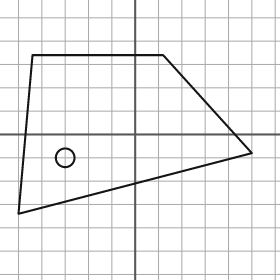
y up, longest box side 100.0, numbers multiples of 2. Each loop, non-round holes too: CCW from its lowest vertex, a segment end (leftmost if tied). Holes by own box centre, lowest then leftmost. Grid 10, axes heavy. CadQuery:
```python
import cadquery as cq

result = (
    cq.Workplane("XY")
    .moveTo(-50.0, -34.0)
    .lineTo(50.0, -8.0)
    .lineTo(12.0, 34.0)
    .lineTo(-44.0, 34.0)
    .close()
    .moveTo(-30.0, -10.0)
    .circle(4.0)
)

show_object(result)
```